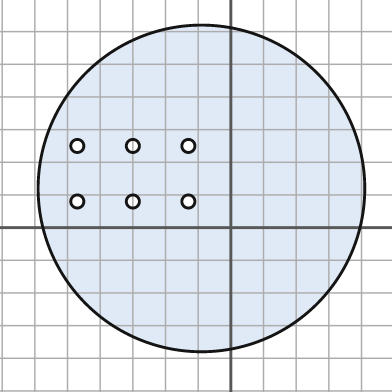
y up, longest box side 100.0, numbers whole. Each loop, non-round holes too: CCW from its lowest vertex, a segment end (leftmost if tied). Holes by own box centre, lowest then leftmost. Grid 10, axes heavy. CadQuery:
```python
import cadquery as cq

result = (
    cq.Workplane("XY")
    .moveTo(-9.0, 12.0)
    .circle(50.0)
    .moveTo(-47.0, 8.0)
    .circle(2.0)
    .moveTo(-30.0, 8.0)
    .circle(2.0)
    .moveTo(-13.0, 8.0)
    .circle(2.0)
    .moveTo(-47.0, 25.0)
    .circle(2.0)
    .moveTo(-30.0, 25.0)
    .circle(2.0)
    .moveTo(-13.0, 25.0)
    .circle(2.0)
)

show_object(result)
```